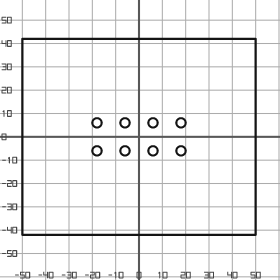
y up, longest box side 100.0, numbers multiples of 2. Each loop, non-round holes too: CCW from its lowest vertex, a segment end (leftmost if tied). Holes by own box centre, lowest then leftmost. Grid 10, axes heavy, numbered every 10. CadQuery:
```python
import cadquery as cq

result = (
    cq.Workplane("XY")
    .moveTo(-50.0, -42.0)
    .lineTo(50.0, -42.0)
    .lineTo(50.0, 42.0)
    .lineTo(-50.0, 42.0)
    .close()
    .moveTo(-18.0, -6.0)
    .circle(2.0)
    .moveTo(-6.0, -6.0)
    .circle(2.0)
    .moveTo(6.0, -6.0)
    .circle(2.0)
    .moveTo(18.0, -6.0)
    .circle(2.0)
    .moveTo(-18.0, 6.0)
    .circle(2.0)
    .moveTo(-6.0, 6.0)
    .circle(2.0)
    .moveTo(6.0, 6.0)
    .circle(2.0)
    .moveTo(18.0, 6.0)
    .circle(2.0)
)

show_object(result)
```